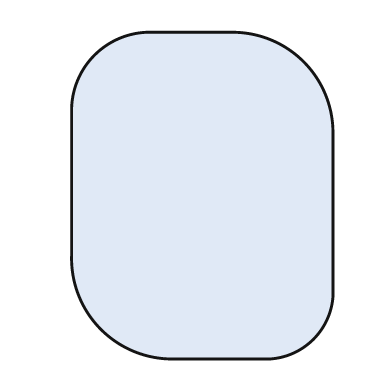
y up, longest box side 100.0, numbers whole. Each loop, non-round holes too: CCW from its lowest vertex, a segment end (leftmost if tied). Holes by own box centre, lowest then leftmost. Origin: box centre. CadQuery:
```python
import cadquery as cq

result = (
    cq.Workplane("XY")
    .moveTo(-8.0, -50.0)
    .lineTo(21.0, -50.0)
    .threePointArc((34.0, -44.0), (40.0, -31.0))
    .lineTo(40.0, 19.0)
    .threePointArc((31.0, 41.0), (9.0, 50.0))
    .lineTo(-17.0, 50.0)
    .threePointArc((-33.0, 43.0), (-40.0, 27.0))
    .lineTo(-40.0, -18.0)
    .threePointArc((-31.0, -41.0), (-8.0, -50.0))
    .close()
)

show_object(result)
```